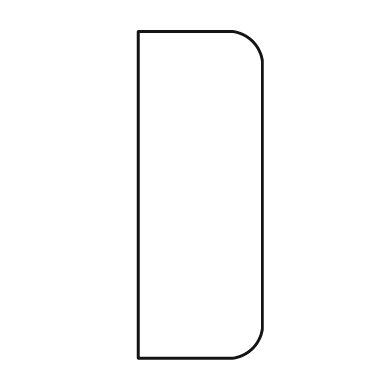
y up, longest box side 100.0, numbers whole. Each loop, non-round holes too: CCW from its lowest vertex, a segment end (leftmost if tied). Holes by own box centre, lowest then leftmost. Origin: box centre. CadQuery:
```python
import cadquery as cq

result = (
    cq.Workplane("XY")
    .moveTo(-19.0, -50.0)
    .lineTo(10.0, -50.0)
    .threePointArc((16.0, -47.0), (19.0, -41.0))
    .lineTo(19.0, 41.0)
    .threePointArc((16.0, 47.0), (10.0, 50.0))
    .lineTo(-19.0, 50.0)
    .close()
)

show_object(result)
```